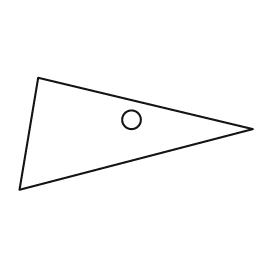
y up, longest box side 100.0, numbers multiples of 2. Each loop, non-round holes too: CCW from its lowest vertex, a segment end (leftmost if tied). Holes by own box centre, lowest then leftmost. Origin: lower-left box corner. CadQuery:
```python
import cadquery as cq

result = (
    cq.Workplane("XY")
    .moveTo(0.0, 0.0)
    .lineTo(100.0, 26.0)
    .lineTo(8.0, 48.0)
    .close()
    .moveTo(48.0, 30.0)
    .circle(4.0)
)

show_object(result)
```